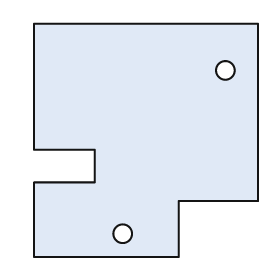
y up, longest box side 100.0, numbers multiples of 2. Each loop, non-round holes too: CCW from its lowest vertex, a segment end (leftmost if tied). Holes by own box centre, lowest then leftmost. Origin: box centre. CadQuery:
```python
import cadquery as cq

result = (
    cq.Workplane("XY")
    .moveTo(-48.0, -50.0)
    .lineTo(14.0, -50.0)
    .lineTo(14.0, -26.0)
    .lineTo(48.0, -26.0)
    .lineTo(48.0, 50.0)
    .lineTo(-48.0, 50.0)
    .lineTo(-48.0, -4.0)
    .lineTo(-22.0, -4.0)
    .lineTo(-22.0, -18.0)
    .lineTo(-48.0, -18.0)
    .close()
    .moveTo(-10.0, -40.0)
    .circle(4.0)
    .moveTo(34.0, 30.0)
    .circle(4.0)
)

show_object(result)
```